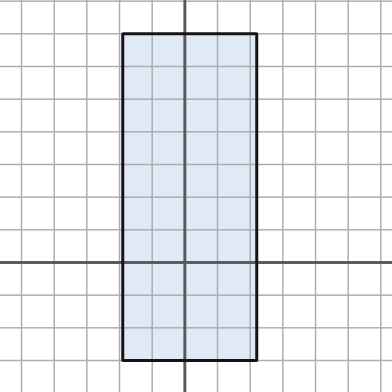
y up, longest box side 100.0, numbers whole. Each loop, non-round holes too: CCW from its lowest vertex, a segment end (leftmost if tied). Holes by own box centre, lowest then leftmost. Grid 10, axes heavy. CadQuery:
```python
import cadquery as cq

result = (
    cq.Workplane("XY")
    .moveTo(-19.0, -30.0)
    .lineTo(22.0, -30.0)
    .lineTo(22.0, 70.0)
    .lineTo(-19.0, 70.0)
    .close()
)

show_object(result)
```